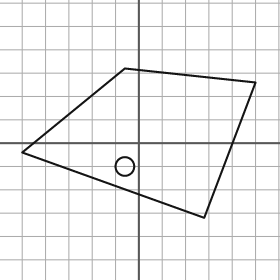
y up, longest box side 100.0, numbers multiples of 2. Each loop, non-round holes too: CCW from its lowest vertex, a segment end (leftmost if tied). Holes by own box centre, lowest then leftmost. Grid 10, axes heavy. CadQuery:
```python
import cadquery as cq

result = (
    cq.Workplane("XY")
    .moveTo(28.0, -32.0)
    .lineTo(50.0, 26.0)
    .lineTo(-6.0, 32.0)
    .lineTo(-50.0, -4.0)
    .close()
    .moveTo(-6.0, -10.0)
    .circle(4.0)
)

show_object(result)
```